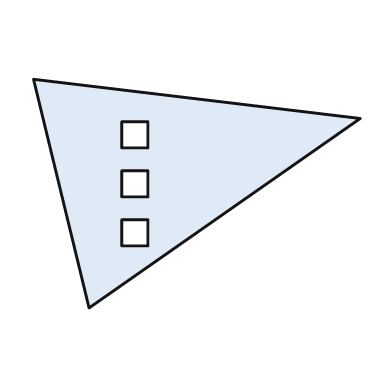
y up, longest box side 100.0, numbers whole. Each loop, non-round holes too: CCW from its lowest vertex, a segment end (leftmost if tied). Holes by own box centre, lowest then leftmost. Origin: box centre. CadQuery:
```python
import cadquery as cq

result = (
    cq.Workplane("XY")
    .moveTo(-33.0, -35.0)
    .lineTo(50.0, 23.0)
    .lineTo(-50.0, 35.0)
    .close()
    .moveTo(-23.0, -16.0)
    .lineTo(-15.0, -16.0)
    .lineTo(-15.0, -8.0)
    .lineTo(-23.0, -8.0)
    .close()
    .moveTo(-23.0, -1.0)
    .lineTo(-15.0, -1.0)
    .lineTo(-15.0, 7.0)
    .lineTo(-23.0, 7.0)
    .close()
    .moveTo(-23.0, 14.0)
    .lineTo(-15.0, 14.0)
    .lineTo(-15.0, 22.0)
    .lineTo(-23.0, 22.0)
    .close()
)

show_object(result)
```